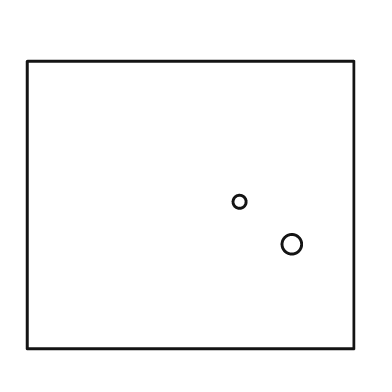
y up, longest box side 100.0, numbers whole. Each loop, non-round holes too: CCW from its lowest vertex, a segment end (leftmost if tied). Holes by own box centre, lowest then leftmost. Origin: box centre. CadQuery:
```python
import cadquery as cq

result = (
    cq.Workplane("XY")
    .moveTo(-50.0, -44.0)
    .lineTo(50.0, -44.0)
    .lineTo(50.0, 44.0)
    .lineTo(-50.0, 44.0)
    .close()
    .moveTo(31.0, -12.0)
    .circle(3.0)
    .moveTo(15.0, 1.0)
    .circle(2.0)
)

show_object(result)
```